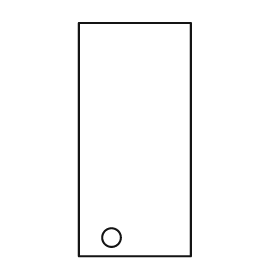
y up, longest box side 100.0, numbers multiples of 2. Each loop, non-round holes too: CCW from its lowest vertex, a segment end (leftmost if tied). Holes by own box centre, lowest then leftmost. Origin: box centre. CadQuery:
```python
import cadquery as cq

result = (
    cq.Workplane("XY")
    .moveTo(-24.0, -50.0)
    .lineTo(24.0, -50.0)
    .lineTo(24.0, 50.0)
    .lineTo(-24.0, 50.0)
    .close()
    .moveTo(-10.0, -42.0)
    .circle(4.0)
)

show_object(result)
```